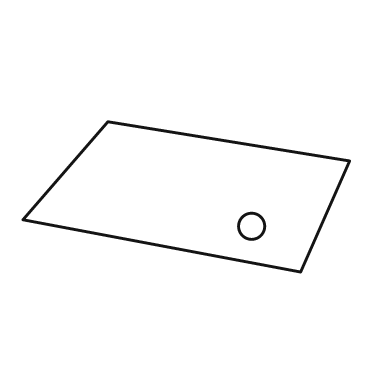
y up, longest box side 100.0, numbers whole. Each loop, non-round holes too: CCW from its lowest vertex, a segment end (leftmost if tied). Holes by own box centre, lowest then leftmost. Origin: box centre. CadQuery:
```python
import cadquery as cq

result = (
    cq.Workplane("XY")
    .moveTo(35.0, -23.0)
    .lineTo(50.0, 11.0)
    .lineTo(-24.0, 23.0)
    .lineTo(-50.0, -7.0)
    .close()
    .moveTo(20.0, -9.0)
    .circle(4.0)
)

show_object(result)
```